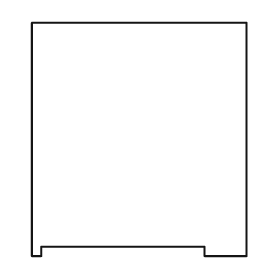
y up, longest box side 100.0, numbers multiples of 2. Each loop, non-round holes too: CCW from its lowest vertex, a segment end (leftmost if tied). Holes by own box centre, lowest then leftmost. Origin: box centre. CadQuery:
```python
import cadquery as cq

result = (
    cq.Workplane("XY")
    .moveTo(-46.0, -50.0)
    .lineTo(-42.0, -50.0)
    .lineTo(-42.0, -46.0)
    .lineTo(28.0, -46.0)
    .lineTo(28.0, -50.0)
    .lineTo(46.0, -50.0)
    .lineTo(46.0, 50.0)
    .lineTo(-46.0, 50.0)
    .close()
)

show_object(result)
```